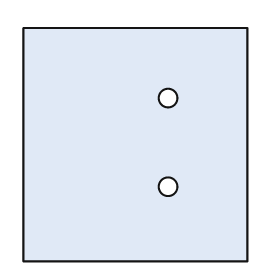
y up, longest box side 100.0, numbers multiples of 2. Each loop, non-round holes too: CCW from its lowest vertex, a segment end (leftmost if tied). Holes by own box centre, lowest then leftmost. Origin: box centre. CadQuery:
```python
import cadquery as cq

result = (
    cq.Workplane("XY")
    .moveTo(-48.0, -50.0)
    .lineTo(48.0, -50.0)
    .lineTo(48.0, 50.0)
    .lineTo(-48.0, 50.0)
    .close()
    .moveTo(14.0, -18.0)
    .circle(4.0)
    .moveTo(14.0, 20.0)
    .circle(4.0)
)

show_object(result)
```